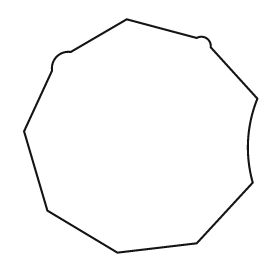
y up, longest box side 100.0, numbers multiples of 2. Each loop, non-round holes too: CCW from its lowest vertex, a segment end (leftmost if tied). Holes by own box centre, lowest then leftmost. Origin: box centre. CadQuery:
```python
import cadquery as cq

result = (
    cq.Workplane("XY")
    .moveTo(-10.0, -50.0)
    .lineTo(24.0, -46.0)
    .lineTo(48.0, -20.0)
    .threePointArc((46.0, -2.0), (50.0, 16.0))
    .lineTo(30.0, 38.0)
    .threePointArc((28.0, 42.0), (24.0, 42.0))
    .lineTo(-6.0, 50.0)
    .lineTo(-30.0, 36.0)
    .threePointArc((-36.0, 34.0), (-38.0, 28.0))
    .lineTo(-50.0, 2.0)
    .lineTo(-40.0, -32.0)
    .close()
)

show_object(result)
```